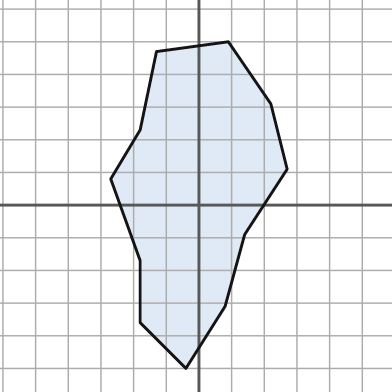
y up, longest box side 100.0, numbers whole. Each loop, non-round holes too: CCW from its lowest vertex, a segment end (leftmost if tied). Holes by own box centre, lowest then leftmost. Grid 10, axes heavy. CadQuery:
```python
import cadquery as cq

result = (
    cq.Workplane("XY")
    .moveTo(-4.0, -50.0)
    .lineTo(8.0, -31.0)
    .lineTo(14.0, -9.0)
    .lineTo(27.0, 11.0)
    .lineTo(22.0, 31.0)
    .lineTo(9.0, 50.0)
    .lineTo(-13.0, 47.0)
    .lineTo(-18.0, 23.0)
    .lineTo(-27.0, 8.0)
    .lineTo(-18.0, -17.0)
    .lineTo(-18.0, -36.0)
    .close()
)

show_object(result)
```